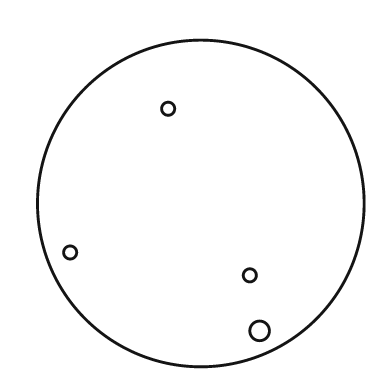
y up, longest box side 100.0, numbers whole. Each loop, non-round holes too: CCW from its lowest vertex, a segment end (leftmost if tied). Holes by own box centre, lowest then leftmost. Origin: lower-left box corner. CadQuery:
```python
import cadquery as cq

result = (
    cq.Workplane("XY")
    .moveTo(50.0, 50.0)
    .circle(50.0)
    .moveTo(68.0, 11.0)
    .circle(3.0)
    .moveTo(65.0, 28.0)
    .circle(2.0)
    .moveTo(10.0, 35.0)
    .circle(2.0)
    .moveTo(40.0, 79.0)
    .circle(2.0)
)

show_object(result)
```